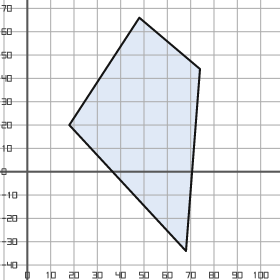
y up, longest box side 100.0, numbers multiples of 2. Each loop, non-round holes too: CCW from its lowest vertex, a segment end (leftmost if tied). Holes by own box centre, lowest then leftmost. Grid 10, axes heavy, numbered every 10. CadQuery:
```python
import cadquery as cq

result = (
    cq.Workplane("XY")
    .moveTo(68.0, -34.0)
    .lineTo(74.0, 44.0)
    .lineTo(48.0, 66.0)
    .lineTo(18.0, 20.0)
    .close()
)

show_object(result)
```